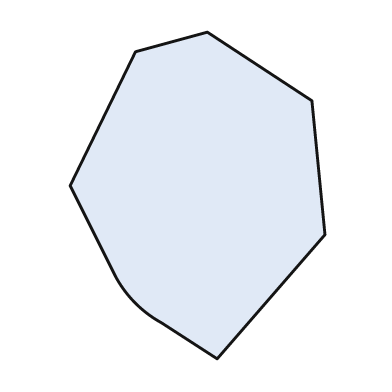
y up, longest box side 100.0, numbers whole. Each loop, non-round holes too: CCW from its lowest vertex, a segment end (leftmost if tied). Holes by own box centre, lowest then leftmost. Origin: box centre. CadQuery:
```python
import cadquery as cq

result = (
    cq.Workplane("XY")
    .moveTo(6.0, -50.0)
    .lineTo(39.0, -12.0)
    .lineTo(35.0, 29.0)
    .lineTo(3.0, 50.0)
    .lineTo(-19.0, 44.0)
    .lineTo(-39.0, 3.0)
    .lineTo(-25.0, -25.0)
    .threePointArc((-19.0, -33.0), (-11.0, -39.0))
    .close()
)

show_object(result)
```